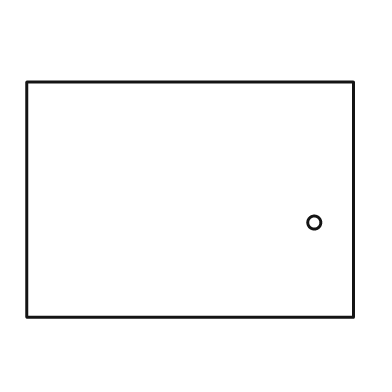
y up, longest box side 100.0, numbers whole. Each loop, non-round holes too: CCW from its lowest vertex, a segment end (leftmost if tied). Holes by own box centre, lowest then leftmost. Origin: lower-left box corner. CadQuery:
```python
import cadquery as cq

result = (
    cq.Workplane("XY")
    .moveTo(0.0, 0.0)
    .lineTo(100.0, 0.0)
    .lineTo(100.0, 72.0)
    .lineTo(0.0, 72.0)
    .close()
    .moveTo(88.0, 29.0)
    .circle(2.0)
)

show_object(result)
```